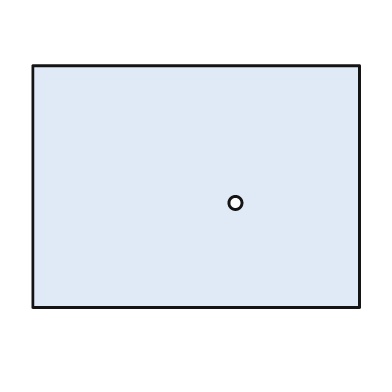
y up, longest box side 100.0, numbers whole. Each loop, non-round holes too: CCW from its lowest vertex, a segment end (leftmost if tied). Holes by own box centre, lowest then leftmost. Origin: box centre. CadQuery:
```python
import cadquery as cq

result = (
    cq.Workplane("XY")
    .moveTo(-50.0, -37.0)
    .lineTo(50.0, -37.0)
    .lineTo(50.0, 37.0)
    .lineTo(-50.0, 37.0)
    .close()
    .moveTo(12.0, -5.0)
    .circle(2.0)
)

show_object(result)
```